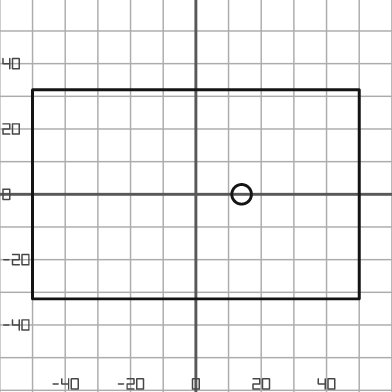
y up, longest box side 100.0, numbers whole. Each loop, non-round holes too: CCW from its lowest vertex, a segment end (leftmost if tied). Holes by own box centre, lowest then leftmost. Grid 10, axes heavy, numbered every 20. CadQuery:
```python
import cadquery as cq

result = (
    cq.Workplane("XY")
    .moveTo(-50.0, -32.0)
    .lineTo(50.0, -32.0)
    .lineTo(50.0, 32.0)
    .lineTo(-50.0, 32.0)
    .close()
    .moveTo(14.0, 0.0)
    .circle(3.0)
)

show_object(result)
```